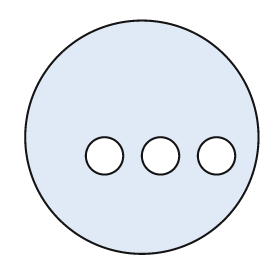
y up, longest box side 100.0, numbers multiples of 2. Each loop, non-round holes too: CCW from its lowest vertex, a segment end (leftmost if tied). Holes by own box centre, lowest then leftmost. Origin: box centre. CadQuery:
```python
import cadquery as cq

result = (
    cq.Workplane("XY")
    .moveTo(0.0, 0.0)
    .circle(50.0)
    .moveTo(-16.0, -8.0)
    .circle(8.0)
    .moveTo(8.0, -8.0)
    .circle(8.0)
    .moveTo(32.0, -8.0)
    .circle(8.0)
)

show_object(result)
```